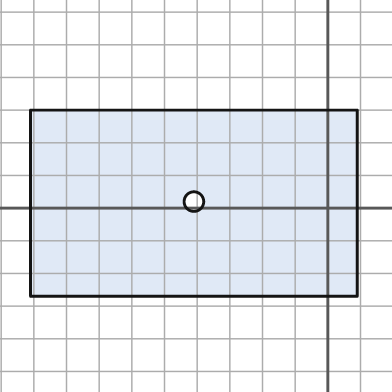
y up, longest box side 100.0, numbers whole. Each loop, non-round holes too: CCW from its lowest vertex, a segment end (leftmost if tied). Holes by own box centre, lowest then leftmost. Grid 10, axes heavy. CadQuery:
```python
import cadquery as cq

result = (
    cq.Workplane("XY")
    .moveTo(-91.0, -27.0)
    .lineTo(9.0, -27.0)
    .lineTo(9.0, 30.0)
    .lineTo(-91.0, 30.0)
    .close()
    .moveTo(-41.0, 2.0)
    .circle(3.0)
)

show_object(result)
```